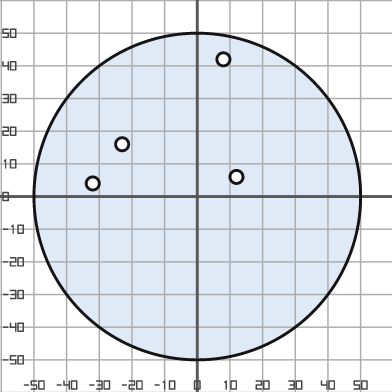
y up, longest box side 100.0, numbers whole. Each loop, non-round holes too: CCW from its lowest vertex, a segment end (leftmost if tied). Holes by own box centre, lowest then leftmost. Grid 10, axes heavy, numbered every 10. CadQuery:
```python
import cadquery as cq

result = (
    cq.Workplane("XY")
    .moveTo(0.0, 0.0)
    .circle(50.0)
    .moveTo(-32.0, 4.0)
    .circle(2.0)
    .moveTo(12.0, 6.0)
    .circle(2.0)
    .moveTo(-23.0, 16.0)
    .circle(2.0)
    .moveTo(8.0, 42.0)
    .circle(2.0)
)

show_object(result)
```